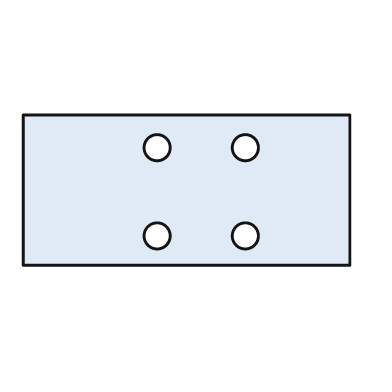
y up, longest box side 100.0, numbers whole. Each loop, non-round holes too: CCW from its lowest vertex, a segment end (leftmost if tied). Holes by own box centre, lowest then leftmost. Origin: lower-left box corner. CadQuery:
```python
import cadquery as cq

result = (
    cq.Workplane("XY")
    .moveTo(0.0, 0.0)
    .lineTo(100.0, 0.0)
    .lineTo(100.0, 46.0)
    .lineTo(0.0, 46.0)
    .close()
    .moveTo(41.0, 9.0)
    .circle(4.0)
    .moveTo(68.0, 9.0)
    .circle(4.0)
    .moveTo(41.0, 36.0)
    .circle(4.0)
    .moveTo(68.0, 36.0)
    .circle(4.0)
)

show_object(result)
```